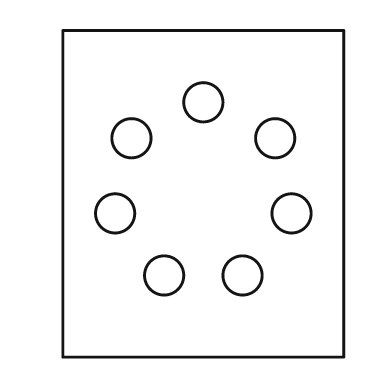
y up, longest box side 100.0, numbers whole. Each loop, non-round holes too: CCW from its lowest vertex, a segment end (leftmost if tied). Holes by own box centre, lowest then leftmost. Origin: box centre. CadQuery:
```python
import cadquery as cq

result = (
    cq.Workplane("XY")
    .moveTo(-43.0, -50.0)
    .lineTo(43.0, -50.0)
    .lineTo(43.0, 50.0)
    .lineTo(-43.0, 50.0)
    .close()
    .moveTo(-12.0, -25.0)
    .circle(6.0)
    .moveTo(12.0, -25.0)
    .circle(6.0)
    .moveTo(-27.0, -6.0)
    .circle(6.0)
    .moveTo(27.0, -6.0)
    .circle(6.0)
    .moveTo(-22.0, 17.0)
    .circle(6.0)
    .moveTo(22.0, 17.0)
    .circle(6.0)
    .moveTo(0.0, 28.0)
    .circle(6.0)
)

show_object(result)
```